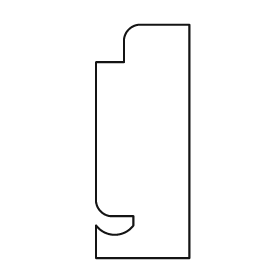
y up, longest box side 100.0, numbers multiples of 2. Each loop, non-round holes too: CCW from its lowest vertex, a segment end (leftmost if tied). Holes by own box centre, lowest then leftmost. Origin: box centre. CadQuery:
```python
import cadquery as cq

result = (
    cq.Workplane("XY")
    .moveTo(-20.0, -50.0)
    .lineTo(20.0, -50.0)
    .lineTo(20.0, 50.0)
    .lineTo(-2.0, 50.0)
    .threePointArc((-6.0, 48.0), (-8.0, 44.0))
    .lineTo(-8.0, 34.0)
    .lineTo(-20.0, 34.0)
    .lineTo(-20.0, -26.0)
    .threePointArc((-18.0, -30.0), (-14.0, -32.0))
    .lineTo(-4.0, -32.0)
    .lineTo(-4.0, -36.0)
    .threePointArc((-12.0, -40.0), (-20.0, -36.0))
    .close()
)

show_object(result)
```